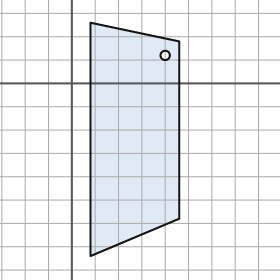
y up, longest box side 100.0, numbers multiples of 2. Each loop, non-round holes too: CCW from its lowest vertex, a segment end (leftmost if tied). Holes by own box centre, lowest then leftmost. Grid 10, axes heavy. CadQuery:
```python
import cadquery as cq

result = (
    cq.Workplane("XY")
    .moveTo(8.0, -74.0)
    .lineTo(46.0, -58.0)
    .lineTo(46.0, 18.0)
    .lineTo(8.0, 26.0)
    .close()
    .moveTo(40.0, 12.0)
    .circle(2.0)
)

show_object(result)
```